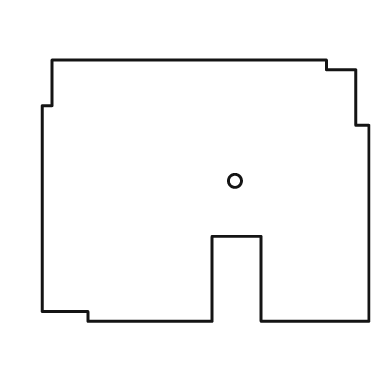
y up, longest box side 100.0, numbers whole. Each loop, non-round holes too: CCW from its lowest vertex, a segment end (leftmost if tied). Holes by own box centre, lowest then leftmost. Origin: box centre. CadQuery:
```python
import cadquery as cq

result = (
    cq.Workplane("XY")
    .moveTo(-36.0, -40.0)
    .lineTo(2.0, -40.0)
    .lineTo(2.0, -14.0)
    .lineTo(17.0, -14.0)
    .lineTo(17.0, -40.0)
    .lineTo(50.0, -40.0)
    .lineTo(50.0, 20.0)
    .lineTo(46.0, 20.0)
    .lineTo(46.0, 37.0)
    .lineTo(37.0, 37.0)
    .lineTo(37.0, 40.0)
    .lineTo(-47.0, 40.0)
    .lineTo(-47.0, 26.0)
    .lineTo(-50.0, 26.0)
    .lineTo(-50.0, -37.0)
    .lineTo(-36.0, -37.0)
    .close()
    .moveTo(9.0, 3.0)
    .circle(2.0)
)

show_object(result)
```